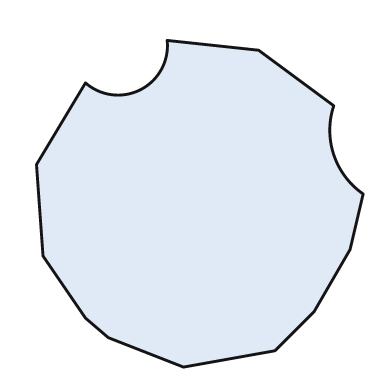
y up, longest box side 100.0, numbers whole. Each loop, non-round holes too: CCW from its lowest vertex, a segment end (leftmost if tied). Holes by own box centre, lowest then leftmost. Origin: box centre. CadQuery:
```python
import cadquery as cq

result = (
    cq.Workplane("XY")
    .moveTo(-5.0, -50.0)
    .lineTo(23.0, -45.0)
    .lineTo(35.0, -33.0)
    .lineTo(46.0, -14.0)
    .lineTo(50.0, 3.0)
    .threePointArc((41.0, 15.0), (41.0, 30.0))
    .lineTo(18.0, 47.0)
    .lineTo(-10.0, 50.0)
    .threePointArc((-18.0, 35.0), (-35.0, 37.0))
    .lineTo(-50.0, 12.0)
    .lineTo(-48.0, -16.0)
    .lineTo(-35.0, -35.0)
    .lineTo(-28.0, -41.0)
    .close()
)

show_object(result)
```